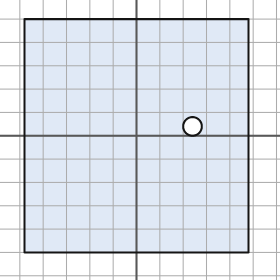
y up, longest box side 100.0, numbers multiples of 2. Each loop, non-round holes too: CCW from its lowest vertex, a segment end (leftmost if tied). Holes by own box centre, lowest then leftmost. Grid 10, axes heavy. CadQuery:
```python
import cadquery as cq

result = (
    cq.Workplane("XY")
    .moveTo(-48.0, -50.0)
    .lineTo(48.0, -50.0)
    .lineTo(48.0, 50.0)
    .lineTo(-48.0, 50.0)
    .close()
    .moveTo(24.0, 4.0)
    .circle(4.0)
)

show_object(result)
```